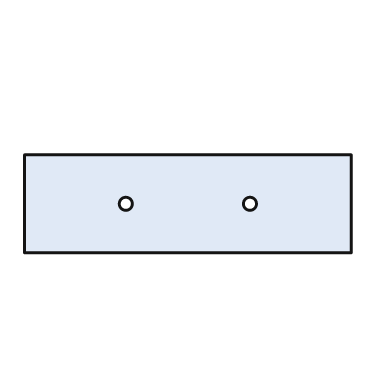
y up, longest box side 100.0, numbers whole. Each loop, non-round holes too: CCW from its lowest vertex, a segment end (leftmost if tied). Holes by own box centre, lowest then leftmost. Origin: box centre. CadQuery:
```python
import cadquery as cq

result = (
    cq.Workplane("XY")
    .moveTo(-50.0, -15.0)
    .lineTo(50.0, -15.0)
    .lineTo(50.0, 15.0)
    .lineTo(-50.0, 15.0)
    .close()
    .moveTo(-19.0, 0.0)
    .circle(2.0)
    .moveTo(19.0, 0.0)
    .circle(2.0)
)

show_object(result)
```